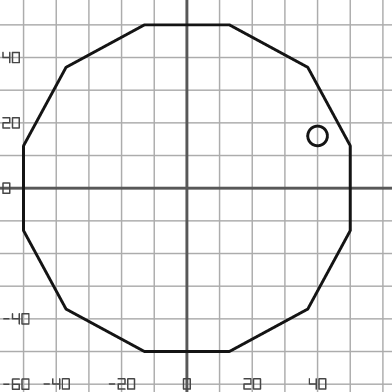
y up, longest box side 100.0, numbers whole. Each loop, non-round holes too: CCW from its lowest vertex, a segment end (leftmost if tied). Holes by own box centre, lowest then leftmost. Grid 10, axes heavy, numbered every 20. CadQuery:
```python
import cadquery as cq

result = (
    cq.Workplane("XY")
    .moveTo(-13.0, -50.0)
    .lineTo(13.0, -50.0)
    .lineTo(37.0, -37.0)
    .lineTo(50.0, -13.0)
    .lineTo(50.0, 13.0)
    .lineTo(37.0, 37.0)
    .lineTo(13.0, 50.0)
    .lineTo(-13.0, 50.0)
    .lineTo(-37.0, 37.0)
    .lineTo(-50.0, 13.0)
    .lineTo(-50.0, -13.0)
    .lineTo(-37.0, -37.0)
    .close()
    .moveTo(40.0, 16.0)
    .circle(3.0)
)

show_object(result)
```